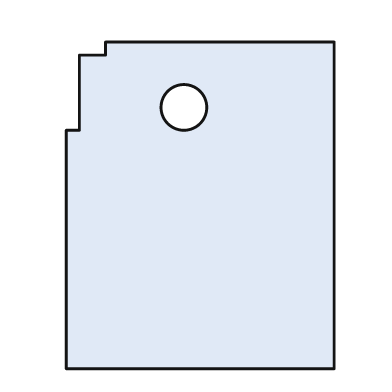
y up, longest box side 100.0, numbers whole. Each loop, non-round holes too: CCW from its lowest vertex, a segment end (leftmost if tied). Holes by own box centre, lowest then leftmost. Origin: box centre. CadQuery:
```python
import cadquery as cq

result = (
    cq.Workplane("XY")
    .moveTo(-41.0, -50.0)
    .lineTo(41.0, -50.0)
    .lineTo(41.0, 50.0)
    .lineTo(-29.0, 50.0)
    .lineTo(-29.0, 46.0)
    .lineTo(-37.0, 46.0)
    .lineTo(-37.0, 23.0)
    .lineTo(-41.0, 23.0)
    .close()
    .moveTo(-5.0, 30.0)
    .circle(7.0)
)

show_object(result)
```